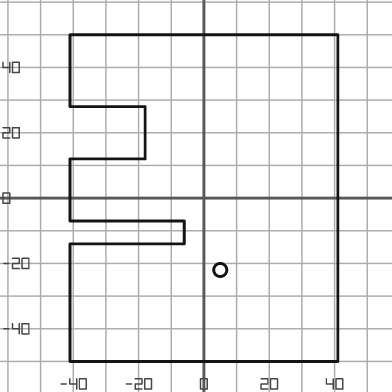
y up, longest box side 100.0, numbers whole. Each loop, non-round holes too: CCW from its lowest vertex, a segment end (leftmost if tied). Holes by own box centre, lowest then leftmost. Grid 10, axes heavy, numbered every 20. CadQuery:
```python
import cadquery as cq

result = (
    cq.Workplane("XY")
    .moveTo(-41.0, -50.0)
    .lineTo(41.0, -50.0)
    .lineTo(41.0, 50.0)
    .lineTo(-41.0, 50.0)
    .lineTo(-41.0, 28.0)
    .lineTo(-18.0, 28.0)
    .lineTo(-18.0, 12.0)
    .lineTo(-41.0, 12.0)
    .lineTo(-41.0, -7.0)
    .lineTo(-6.0, -7.0)
    .lineTo(-6.0, -14.0)
    .lineTo(-41.0, -14.0)
    .close()
    .moveTo(5.0, -22.0)
    .circle(2.0)
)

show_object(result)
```